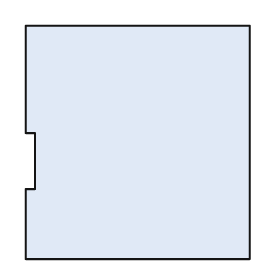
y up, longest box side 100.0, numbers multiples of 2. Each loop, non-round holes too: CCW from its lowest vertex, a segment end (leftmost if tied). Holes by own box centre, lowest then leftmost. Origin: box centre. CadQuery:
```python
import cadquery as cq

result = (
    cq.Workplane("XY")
    .moveTo(-48.0, -50.0)
    .lineTo(48.0, -50.0)
    .lineTo(48.0, 50.0)
    .lineTo(-48.0, 50.0)
    .lineTo(-48.0, 4.0)
    .lineTo(-44.0, 4.0)
    .lineTo(-44.0, -20.0)
    .lineTo(-48.0, -20.0)
    .close()
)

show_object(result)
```